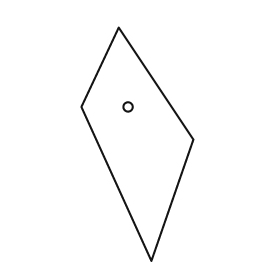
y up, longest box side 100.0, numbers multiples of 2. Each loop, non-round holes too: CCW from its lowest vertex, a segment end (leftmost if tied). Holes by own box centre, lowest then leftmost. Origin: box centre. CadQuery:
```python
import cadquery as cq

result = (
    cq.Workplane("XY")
    .moveTo(6.0, -50.0)
    .lineTo(24.0, 2.0)
    .lineTo(-8.0, 50.0)
    .lineTo(-24.0, 16.0)
    .close()
    .moveTo(-4.0, 16.0)
    .circle(2.0)
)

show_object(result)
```